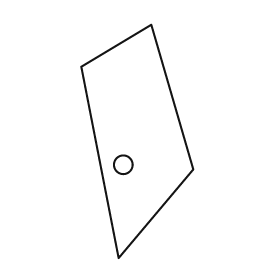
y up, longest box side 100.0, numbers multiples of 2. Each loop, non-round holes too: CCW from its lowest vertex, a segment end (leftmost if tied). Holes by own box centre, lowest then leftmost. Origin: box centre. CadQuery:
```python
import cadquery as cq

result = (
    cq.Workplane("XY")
    .moveTo(-8.0, -50.0)
    .lineTo(24.0, -12.0)
    .lineTo(6.0, 50.0)
    .lineTo(-24.0, 32.0)
    .close()
    .moveTo(-6.0, -10.0)
    .circle(4.0)
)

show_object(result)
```